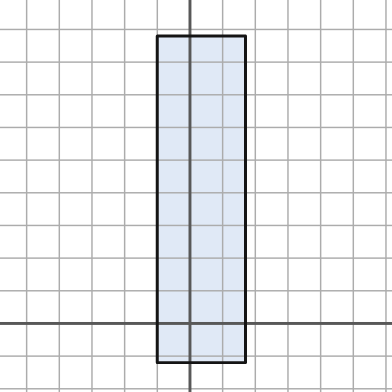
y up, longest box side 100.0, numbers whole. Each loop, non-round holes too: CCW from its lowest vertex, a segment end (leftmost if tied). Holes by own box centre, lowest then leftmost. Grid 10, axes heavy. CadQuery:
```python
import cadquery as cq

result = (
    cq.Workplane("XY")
    .moveTo(-10.0, -12.0)
    .lineTo(17.0, -12.0)
    .lineTo(17.0, 88.0)
    .lineTo(-10.0, 88.0)
    .close()
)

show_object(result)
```